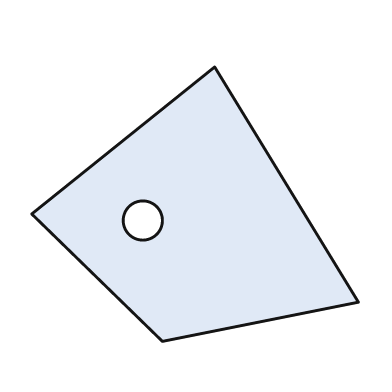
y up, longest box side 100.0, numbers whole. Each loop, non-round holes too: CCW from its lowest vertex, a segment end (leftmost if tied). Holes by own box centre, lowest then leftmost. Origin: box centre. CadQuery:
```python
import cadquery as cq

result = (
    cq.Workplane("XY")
    .moveTo(-10.0, -42.0)
    .lineTo(50.0, -30.0)
    .lineTo(6.0, 42.0)
    .lineTo(-50.0, -3.0)
    .close()
    .moveTo(-16.0, -5.0)
    .circle(6.0)
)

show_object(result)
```